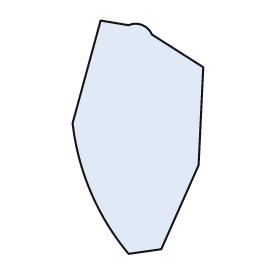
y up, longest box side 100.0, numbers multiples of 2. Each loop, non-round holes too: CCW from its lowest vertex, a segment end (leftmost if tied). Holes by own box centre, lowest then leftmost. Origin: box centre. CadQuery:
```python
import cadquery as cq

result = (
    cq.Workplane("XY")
    .moveTo(-4.0, -50.0)
    .lineTo(10.0, -48.0)
    .lineTo(26.0, -12.0)
    .lineTo(28.0, 30.0)
    .lineTo(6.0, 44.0)
    .threePointArc((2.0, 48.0), (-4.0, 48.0))
    .lineTo(-16.0, 50.0)
    .lineTo(-28.0, 6.0)
    .threePointArc((-20.0, -24.0), (-4.0, -50.0))
    .close()
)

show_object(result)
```